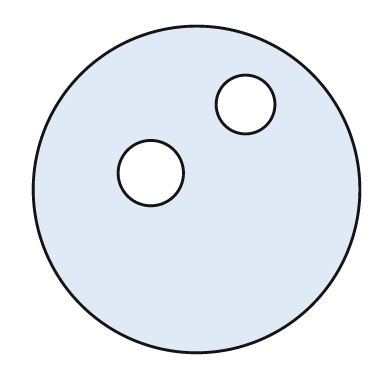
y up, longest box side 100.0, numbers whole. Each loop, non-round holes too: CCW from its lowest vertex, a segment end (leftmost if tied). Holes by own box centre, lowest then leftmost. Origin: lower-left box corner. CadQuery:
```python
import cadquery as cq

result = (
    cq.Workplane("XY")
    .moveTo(50.0, 50.0)
    .circle(50.0)
    .moveTo(36.0, 55.0)
    .circle(10.0)
    .moveTo(65.0, 76.0)
    .circle(9.0)
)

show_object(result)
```